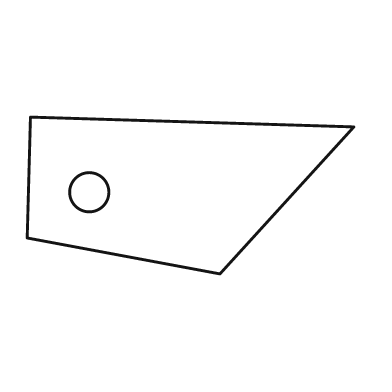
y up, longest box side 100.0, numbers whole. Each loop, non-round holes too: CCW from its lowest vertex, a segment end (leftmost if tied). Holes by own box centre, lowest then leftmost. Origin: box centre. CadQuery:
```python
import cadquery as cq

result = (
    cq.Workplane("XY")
    .moveTo(9.0, -24.0)
    .lineTo(50.0, 21.0)
    .lineTo(-49.0, 24.0)
    .lineTo(-50.0, -13.0)
    .close()
    .moveTo(-31.0, 1.0)
    .circle(6.0)
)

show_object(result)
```